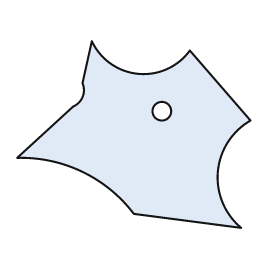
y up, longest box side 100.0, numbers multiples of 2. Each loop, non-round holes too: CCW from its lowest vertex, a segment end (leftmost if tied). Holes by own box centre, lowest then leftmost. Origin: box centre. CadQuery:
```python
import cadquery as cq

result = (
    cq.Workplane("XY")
    .moveTo(46.0, -40.0)
    .threePointArc((36.0, -16.0), (50.0, 6.0))
    .lineTo(24.0, 36.0)
    .threePointArc((2.0, 26.0), (-18.0, 40.0))
    .lineTo(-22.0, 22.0)
    .threePointArc((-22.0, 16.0), (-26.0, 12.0))
    .lineTo(-50.0, -10.0)
    .threePointArc((-22.0, -16.0), (0.0, -34.0))
    .close()
    .moveTo(12.0, 10.0)
    .circle(4.0)
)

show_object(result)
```